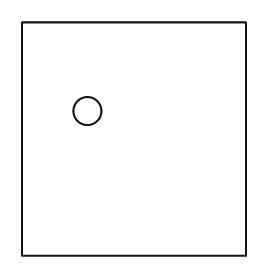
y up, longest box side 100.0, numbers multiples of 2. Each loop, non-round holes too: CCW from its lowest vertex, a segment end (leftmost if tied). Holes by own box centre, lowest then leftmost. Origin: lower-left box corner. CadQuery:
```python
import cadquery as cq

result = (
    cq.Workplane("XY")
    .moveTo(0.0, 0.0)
    .lineTo(96.0, 0.0)
    .lineTo(96.0, 100.0)
    .lineTo(0.0, 100.0)
    .close()
    .moveTo(28.0, 62.0)
    .circle(6.0)
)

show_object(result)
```